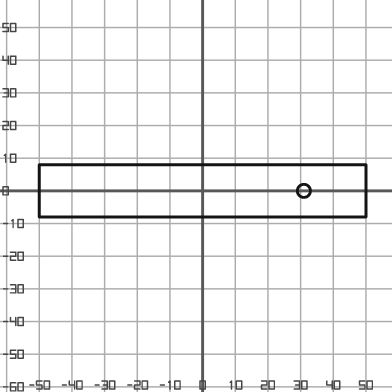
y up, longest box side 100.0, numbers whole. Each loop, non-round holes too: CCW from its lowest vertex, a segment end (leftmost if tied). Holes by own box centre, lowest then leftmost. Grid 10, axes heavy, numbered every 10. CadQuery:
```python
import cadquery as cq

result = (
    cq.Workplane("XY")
    .moveTo(-50.0, -8.0)
    .lineTo(50.0, -8.0)
    .lineTo(50.0, 8.0)
    .lineTo(-50.0, 8.0)
    .close()
    .moveTo(31.0, 0.0)
    .circle(2.0)
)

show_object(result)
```